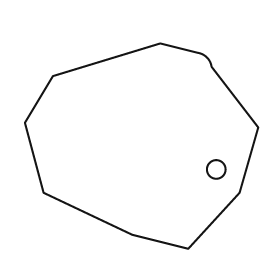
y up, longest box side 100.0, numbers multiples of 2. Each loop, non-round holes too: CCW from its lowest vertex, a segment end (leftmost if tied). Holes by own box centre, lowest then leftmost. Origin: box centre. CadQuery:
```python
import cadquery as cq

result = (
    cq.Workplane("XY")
    .moveTo(20.0, -44.0)
    .lineTo(42.0, -20.0)
    .lineTo(50.0, 8.0)
    .lineTo(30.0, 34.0)
    .threePointArc((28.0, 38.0), (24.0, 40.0))
    .lineTo(8.0, 44.0)
    .lineTo(-38.0, 30.0)
    .lineTo(-50.0, 10.0)
    .lineTo(-42.0, -20.0)
    .lineTo(-4.0, -38.0)
    .close()
    .moveTo(32.0, -10.0)
    .circle(4.0)
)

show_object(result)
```